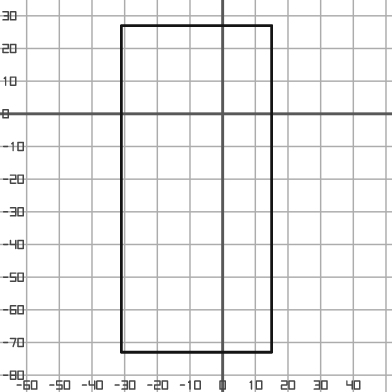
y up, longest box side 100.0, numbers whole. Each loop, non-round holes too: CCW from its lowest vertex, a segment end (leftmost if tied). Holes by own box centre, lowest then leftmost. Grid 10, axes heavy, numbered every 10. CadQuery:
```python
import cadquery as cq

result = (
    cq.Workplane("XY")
    .moveTo(-31.0, -73.0)
    .lineTo(15.0, -73.0)
    .lineTo(15.0, 27.0)
    .lineTo(-31.0, 27.0)
    .close()
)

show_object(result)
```